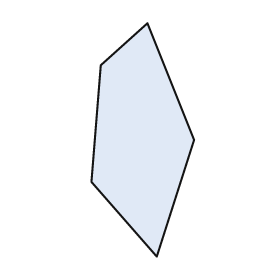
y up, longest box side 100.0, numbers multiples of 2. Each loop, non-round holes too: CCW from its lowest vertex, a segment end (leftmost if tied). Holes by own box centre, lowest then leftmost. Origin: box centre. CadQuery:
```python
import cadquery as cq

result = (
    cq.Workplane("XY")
    .moveTo(6.0, -50.0)
    .lineTo(22.0, 0.0)
    .lineTo(2.0, 50.0)
    .lineTo(-18.0, 32.0)
    .lineTo(-22.0, -18.0)
    .close()
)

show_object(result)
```